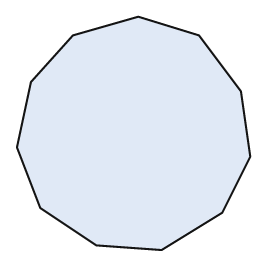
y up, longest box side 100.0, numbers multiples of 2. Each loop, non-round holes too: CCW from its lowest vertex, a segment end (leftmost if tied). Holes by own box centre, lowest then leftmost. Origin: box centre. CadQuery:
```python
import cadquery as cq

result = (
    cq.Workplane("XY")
    .moveTo(12.0, -50.0)
    .lineTo(38.0, -34.0)
    .lineTo(50.0, -10.0)
    .lineTo(46.0, 18.0)
    .lineTo(28.0, 42.0)
    .lineTo(2.0, 50.0)
    .lineTo(-26.0, 42.0)
    .lineTo(-44.0, 22.0)
    .lineTo(-50.0, -6.0)
    .lineTo(-40.0, -32.0)
    .lineTo(-16.0, -48.0)
    .close()
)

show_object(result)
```